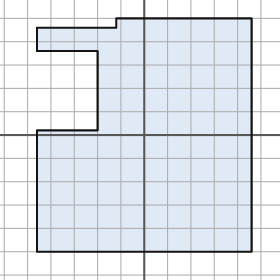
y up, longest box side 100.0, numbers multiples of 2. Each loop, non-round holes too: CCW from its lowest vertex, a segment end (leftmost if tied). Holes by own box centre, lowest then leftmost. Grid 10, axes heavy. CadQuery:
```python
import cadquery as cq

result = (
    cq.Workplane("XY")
    .moveTo(-46.0, -50.0)
    .lineTo(46.0, -50.0)
    .lineTo(46.0, 50.0)
    .lineTo(-12.0, 50.0)
    .lineTo(-12.0, 46.0)
    .lineTo(-46.0, 46.0)
    .lineTo(-46.0, 36.0)
    .lineTo(-20.0, 36.0)
    .lineTo(-20.0, 2.0)
    .lineTo(-46.0, 2.0)
    .close()
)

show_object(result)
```